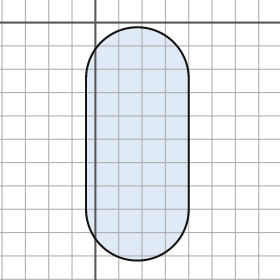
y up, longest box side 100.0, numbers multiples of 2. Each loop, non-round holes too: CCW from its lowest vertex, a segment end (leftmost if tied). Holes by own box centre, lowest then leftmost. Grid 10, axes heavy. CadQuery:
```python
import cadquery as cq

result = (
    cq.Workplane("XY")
    .moveTo(-4.0, -80.0)
    .threePointArc((18.0, -102.0), (40.0, -80.0))
    .lineTo(40.0, -24.0)
    .threePointArc((18.0, -2.0), (-4.0, -24.0))
    .close()
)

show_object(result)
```